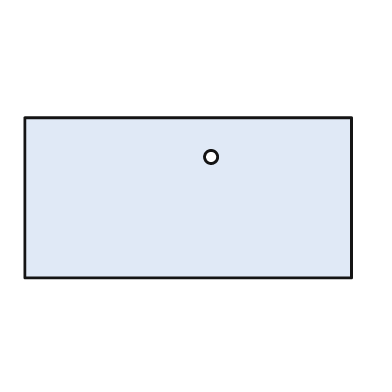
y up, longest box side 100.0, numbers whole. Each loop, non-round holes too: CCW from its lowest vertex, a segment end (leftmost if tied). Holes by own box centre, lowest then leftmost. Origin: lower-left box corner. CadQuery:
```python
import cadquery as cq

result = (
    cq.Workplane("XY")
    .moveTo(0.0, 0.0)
    .lineTo(100.0, 0.0)
    .lineTo(100.0, 49.0)
    .lineTo(0.0, 49.0)
    .close()
    .moveTo(57.0, 37.0)
    .circle(2.0)
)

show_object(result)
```